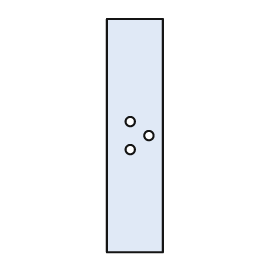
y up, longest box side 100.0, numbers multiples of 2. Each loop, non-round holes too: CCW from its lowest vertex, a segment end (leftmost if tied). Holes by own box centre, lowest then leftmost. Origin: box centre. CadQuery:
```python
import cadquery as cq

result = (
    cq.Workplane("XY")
    .moveTo(-12.0, -50.0)
    .lineTo(12.0, -50.0)
    .lineTo(12.0, 50.0)
    .lineTo(-12.0, 50.0)
    .close()
    .moveTo(-2.0, -6.0)
    .circle(2.0)
    .moveTo(6.0, 0.0)
    .circle(2.0)
    .moveTo(-2.0, 6.0)
    .circle(2.0)
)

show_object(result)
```